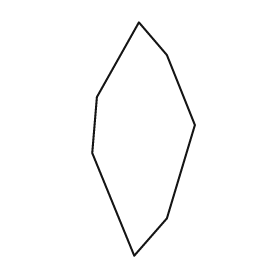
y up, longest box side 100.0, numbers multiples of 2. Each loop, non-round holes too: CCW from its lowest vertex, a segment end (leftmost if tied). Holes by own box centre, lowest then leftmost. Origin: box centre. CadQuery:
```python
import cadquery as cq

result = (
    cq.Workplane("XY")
    .moveTo(-4.0, -50.0)
    .lineTo(10.0, -34.0)
    .lineTo(22.0, 6.0)
    .lineTo(10.0, 36.0)
    .lineTo(-2.0, 50.0)
    .lineTo(-20.0, 18.0)
    .lineTo(-22.0, -6.0)
    .close()
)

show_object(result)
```